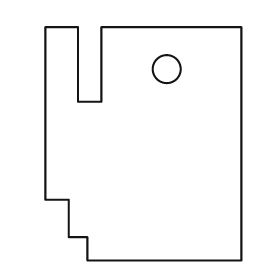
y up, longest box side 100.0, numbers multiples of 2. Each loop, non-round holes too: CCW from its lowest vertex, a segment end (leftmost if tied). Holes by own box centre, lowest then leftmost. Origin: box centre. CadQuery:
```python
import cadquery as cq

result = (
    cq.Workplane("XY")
    .moveTo(-24.0, -50.0)
    .lineTo(42.0, -50.0)
    .lineTo(42.0, 50.0)
    .lineTo(-18.0, 50.0)
    .lineTo(-18.0, 18.0)
    .lineTo(-28.0, 18.0)
    .lineTo(-28.0, 50.0)
    .lineTo(-42.0, 50.0)
    .lineTo(-42.0, -24.0)
    .lineTo(-32.0, -24.0)
    .lineTo(-32.0, -40.0)
    .lineTo(-24.0, -40.0)
    .close()
    .moveTo(10.0, 32.0)
    .circle(6.0)
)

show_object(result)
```